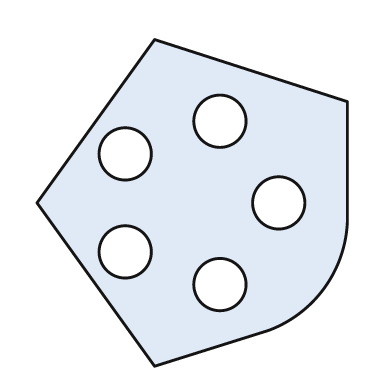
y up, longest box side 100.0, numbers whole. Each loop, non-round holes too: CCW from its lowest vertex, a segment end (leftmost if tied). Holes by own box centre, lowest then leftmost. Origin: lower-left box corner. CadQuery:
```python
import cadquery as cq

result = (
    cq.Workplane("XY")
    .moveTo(36.0, 0.0)
    .lineTo(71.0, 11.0)
    .threePointArc((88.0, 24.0), (95.0, 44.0))
    .lineTo(95.0, 81.0)
    .lineTo(36.0, 100.0)
    .lineTo(0.0, 50.0)
    .close()
    .moveTo(56.0, 25.0)
    .circle(8.0)
    .moveTo(27.0, 35.0)
    .circle(8.0)
    .moveTo(74.0, 50.0)
    .circle(8.0)
    .moveTo(27.0, 65.0)
    .circle(8.0)
    .moveTo(56.0, 75.0)
    .circle(8.0)
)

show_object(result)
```